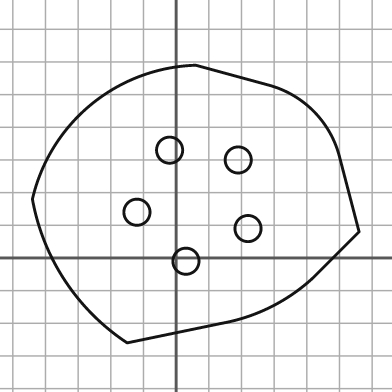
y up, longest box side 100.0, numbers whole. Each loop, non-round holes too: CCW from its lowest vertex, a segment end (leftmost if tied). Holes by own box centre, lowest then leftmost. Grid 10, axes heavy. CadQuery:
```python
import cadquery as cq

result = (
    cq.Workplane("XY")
    .moveTo(-15.0, -26.0)
    .lineTo(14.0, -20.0)
    .threePointArc((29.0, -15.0), (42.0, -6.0))
    .lineTo(56.0, 8.0)
    .lineTo(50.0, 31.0)
    .threePointArc((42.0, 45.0), (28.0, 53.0))
    .lineTo(6.0, 59.0)
    .threePointArc((-26.0, 47.0), (-44.0, 18.0))
    .threePointArc((-34.0, -7.0), (-15.0, -26.0))
    .close()
    .moveTo(3.0, -1.0)
    .circle(4.0)
    .moveTo(22.0, 9.0)
    .circle(4.0)
    .moveTo(-12.0, 14.0)
    .circle(4.0)
    .moveTo(19.0, 30.0)
    .circle(4.0)
    .moveTo(-2.0, 33.0)
    .circle(4.0)
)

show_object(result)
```